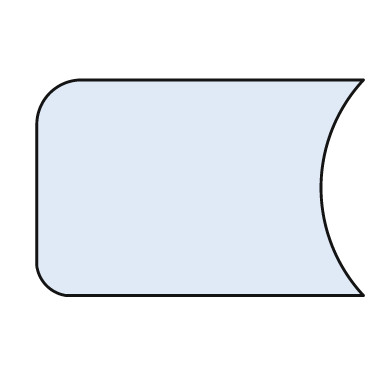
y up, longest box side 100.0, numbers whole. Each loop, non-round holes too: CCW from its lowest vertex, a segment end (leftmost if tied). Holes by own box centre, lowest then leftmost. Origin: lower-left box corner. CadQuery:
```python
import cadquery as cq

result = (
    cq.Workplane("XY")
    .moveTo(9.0, 0.0)
    .lineTo(100.0, 0.0)
    .threePointArc((87.0, 33.0), (100.0, 66.0))
    .lineTo(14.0, 66.0)
    .threePointArc((4.0, 62.0), (0.0, 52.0))
    .lineTo(0.0, 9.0)
    .threePointArc((3.0, 3.0), (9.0, 0.0))
    .close()
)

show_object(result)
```